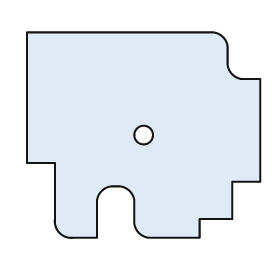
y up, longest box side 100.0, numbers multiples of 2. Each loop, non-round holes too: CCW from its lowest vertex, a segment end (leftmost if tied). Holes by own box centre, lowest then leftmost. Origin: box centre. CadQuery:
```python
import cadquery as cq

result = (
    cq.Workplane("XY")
    .moveTo(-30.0, -44.0)
    .lineTo(-20.0, -44.0)
    .lineTo(-20.0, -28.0)
    .threePointArc((-18.0, -24.0), (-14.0, -22.0))
    .lineTo(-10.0, -22.0)
    .threePointArc((-6.0, -24.0), (-4.0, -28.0))
    .lineTo(-4.0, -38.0)
    .threePointArc((-2.0, -42.0), (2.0, -44.0))
    .lineTo(24.0, -44.0)
    .lineTo(24.0, -36.0)
    .lineTo(38.0, -36.0)
    .lineTo(38.0, -20.0)
    .lineTo(50.0, -20.0)
    .lineTo(50.0, 24.0)
    .lineTo(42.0, 24.0)
    .threePointArc((38.0, 26.0), (36.0, 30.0))
    .lineTo(36.0, 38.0)
    .threePointArc((34.0, 42.0), (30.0, 44.0))
    .lineTo(-50.0, 44.0)
    .lineTo(-50.0, -12.0)
    .lineTo(-38.0, -12.0)
    .lineTo(-38.0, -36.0)
    .threePointArc((-36.0, -42.0), (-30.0, -44.0))
    .close()
    .moveTo(0.0, 0.0)
    .circle(4.0)
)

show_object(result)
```